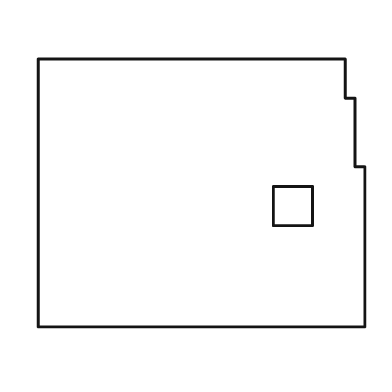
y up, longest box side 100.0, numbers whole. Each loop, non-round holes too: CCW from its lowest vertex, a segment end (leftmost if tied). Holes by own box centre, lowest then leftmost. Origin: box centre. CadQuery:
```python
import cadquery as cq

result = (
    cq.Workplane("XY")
    .moveTo(-50.0, -41.0)
    .lineTo(50.0, -41.0)
    .lineTo(50.0, 8.0)
    .lineTo(47.0, 8.0)
    .lineTo(47.0, 29.0)
    .lineTo(44.0, 29.0)
    .lineTo(44.0, 41.0)
    .lineTo(-50.0, 41.0)
    .close()
    .moveTo(22.0, -10.0)
    .lineTo(34.0, -10.0)
    .lineTo(34.0, 2.0)
    .lineTo(22.0, 2.0)
    .close()
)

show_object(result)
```